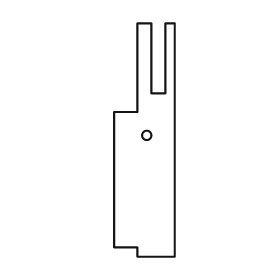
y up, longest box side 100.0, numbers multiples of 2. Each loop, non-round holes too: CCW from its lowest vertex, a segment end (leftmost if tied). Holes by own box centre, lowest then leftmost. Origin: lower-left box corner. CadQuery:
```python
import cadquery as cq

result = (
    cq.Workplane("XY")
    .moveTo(10.0, 0.0)
    .lineTo(26.0, 0.0)
    .lineTo(26.0, 100.0)
    .lineTo(22.0, 100.0)
    .lineTo(22.0, 70.0)
    .lineTo(16.0, 70.0)
    .lineTo(16.0, 100.0)
    .lineTo(10.0, 100.0)
    .lineTo(10.0, 62.0)
    .lineTo(0.0, 62.0)
    .lineTo(0.0, 4.0)
    .lineTo(10.0, 4.0)
    .close()
    .moveTo(14.0, 52.0)
    .circle(2.0)
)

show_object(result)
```